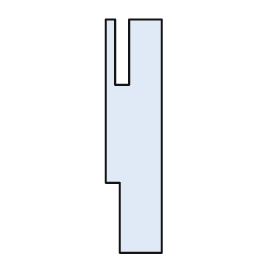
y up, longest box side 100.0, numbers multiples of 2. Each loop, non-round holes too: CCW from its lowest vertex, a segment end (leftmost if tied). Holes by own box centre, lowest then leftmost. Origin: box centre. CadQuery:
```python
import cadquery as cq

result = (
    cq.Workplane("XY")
    .moveTo(-6.0, -50.0)
    .lineTo(12.0, -50.0)
    .lineTo(12.0, 50.0)
    .lineTo(-2.0, 50.0)
    .lineTo(-2.0, 22.0)
    .lineTo(-8.0, 22.0)
    .lineTo(-8.0, 50.0)
    .lineTo(-12.0, 50.0)
    .lineTo(-12.0, -20.0)
    .lineTo(-6.0, -20.0)
    .close()
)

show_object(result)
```